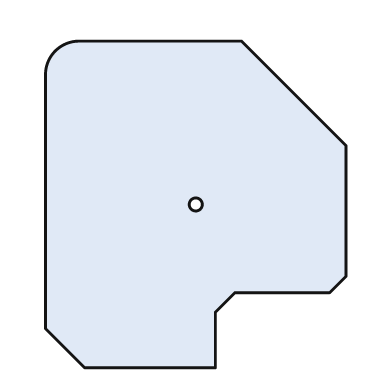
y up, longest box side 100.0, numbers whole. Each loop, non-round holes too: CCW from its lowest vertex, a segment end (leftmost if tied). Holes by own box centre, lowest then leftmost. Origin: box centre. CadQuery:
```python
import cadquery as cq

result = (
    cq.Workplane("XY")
    .moveTo(-34.0, -50.0)
    .lineTo(6.0, -50.0)
    .lineTo(6.0, -33.0)
    .lineTo(12.0, -27.0)
    .lineTo(41.0, -27.0)
    .lineTo(46.0, -22.0)
    .lineTo(46.0, 18.0)
    .lineTo(14.0, 50.0)
    .lineTo(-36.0, 50.0)
    .threePointArc((-43.0, 47.0), (-46.0, 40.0))
    .lineTo(-46.0, -38.0)
    .close()
    .moveTo(0.0, 0.0)
    .circle(2.0)
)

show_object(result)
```